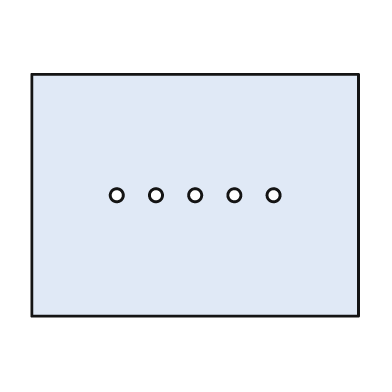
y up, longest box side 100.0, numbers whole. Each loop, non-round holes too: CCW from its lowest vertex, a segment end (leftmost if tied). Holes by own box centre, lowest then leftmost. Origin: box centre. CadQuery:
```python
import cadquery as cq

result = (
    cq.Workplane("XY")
    .moveTo(-50.0, -37.0)
    .lineTo(50.0, -37.0)
    .lineTo(50.0, 37.0)
    .lineTo(-50.0, 37.0)
    .close()
    .moveTo(-24.0, 0.0)
    .circle(2.0)
    .moveTo(-12.0, 0.0)
    .circle(2.0)
    .moveTo(0.0, 0.0)
    .circle(2.0)
    .moveTo(12.0, 0.0)
    .circle(2.0)
    .moveTo(24.0, 0.0)
    .circle(2.0)
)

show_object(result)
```